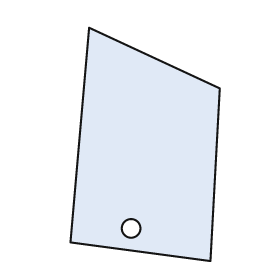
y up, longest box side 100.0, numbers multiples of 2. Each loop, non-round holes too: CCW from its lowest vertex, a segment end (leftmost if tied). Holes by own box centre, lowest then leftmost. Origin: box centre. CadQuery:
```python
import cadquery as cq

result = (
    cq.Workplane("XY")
    .moveTo(28.0, -50.0)
    .lineTo(32.0, 24.0)
    .lineTo(-24.0, 50.0)
    .lineTo(-32.0, -42.0)
    .close()
    .moveTo(-6.0, -36.0)
    .circle(4.0)
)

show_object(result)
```